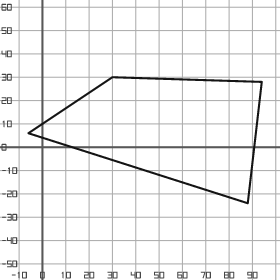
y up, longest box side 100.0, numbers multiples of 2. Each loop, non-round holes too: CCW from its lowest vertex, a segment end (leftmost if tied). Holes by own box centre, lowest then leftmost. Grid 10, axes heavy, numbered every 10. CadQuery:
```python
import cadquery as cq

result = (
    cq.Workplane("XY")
    .moveTo(88.0, -24.0)
    .lineTo(94.0, 28.0)
    .lineTo(30.0, 30.0)
    .lineTo(-6.0, 6.0)
    .close()
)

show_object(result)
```